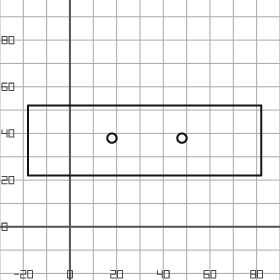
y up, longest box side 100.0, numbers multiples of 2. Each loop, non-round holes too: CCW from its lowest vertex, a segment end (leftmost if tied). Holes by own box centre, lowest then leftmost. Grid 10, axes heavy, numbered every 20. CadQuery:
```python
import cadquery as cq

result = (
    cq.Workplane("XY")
    .moveTo(-18.0, 22.0)
    .lineTo(82.0, 22.0)
    .lineTo(82.0, 52.0)
    .lineTo(-18.0, 52.0)
    .close()
    .moveTo(18.0, 38.0)
    .circle(2.0)
    .moveTo(48.0, 38.0)
    .circle(2.0)
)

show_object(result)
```